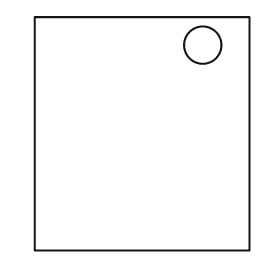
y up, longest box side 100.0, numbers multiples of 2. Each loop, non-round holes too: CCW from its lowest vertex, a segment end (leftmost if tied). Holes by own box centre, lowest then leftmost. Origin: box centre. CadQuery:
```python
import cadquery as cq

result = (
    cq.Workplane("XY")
    .moveTo(-46.0, -50.0)
    .lineTo(46.0, -50.0)
    .lineTo(46.0, 50.0)
    .lineTo(-46.0, 50.0)
    .close()
    .moveTo(26.0, 38.0)
    .circle(8.0)
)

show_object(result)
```